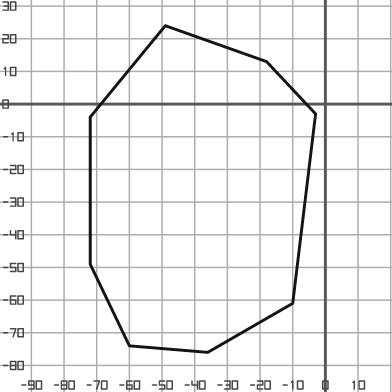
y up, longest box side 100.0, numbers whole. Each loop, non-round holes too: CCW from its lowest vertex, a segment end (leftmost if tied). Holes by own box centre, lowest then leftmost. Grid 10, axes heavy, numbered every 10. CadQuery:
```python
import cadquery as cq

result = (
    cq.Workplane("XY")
    .moveTo(-36.0, -76.0)
    .lineTo(-10.0, -61.0)
    .lineTo(-3.0, -3.0)
    .lineTo(-18.0, 13.0)
    .lineTo(-49.0, 24.0)
    .lineTo(-72.0, -4.0)
    .lineTo(-72.0, -49.0)
    .lineTo(-60.0, -74.0)
    .close()
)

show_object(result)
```